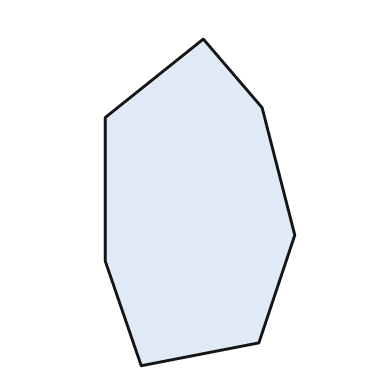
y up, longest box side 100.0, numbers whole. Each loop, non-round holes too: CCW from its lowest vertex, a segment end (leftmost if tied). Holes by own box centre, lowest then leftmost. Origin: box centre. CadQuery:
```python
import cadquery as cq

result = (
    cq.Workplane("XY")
    .moveTo(-18.0, -50.0)
    .lineTo(18.0, -43.0)
    .lineTo(29.0, -10.0)
    .lineTo(19.0, 29.0)
    .lineTo(1.0, 50.0)
    .lineTo(-29.0, 26.0)
    .lineTo(-29.0, -18.0)
    .close()
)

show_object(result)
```